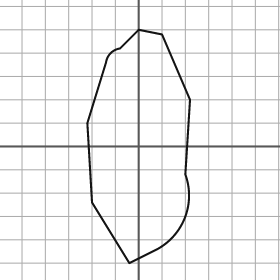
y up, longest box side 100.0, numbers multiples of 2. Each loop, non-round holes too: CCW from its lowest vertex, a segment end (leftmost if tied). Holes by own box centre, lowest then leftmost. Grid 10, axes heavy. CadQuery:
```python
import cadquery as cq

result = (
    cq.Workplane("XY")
    .moveTo(-4.0, -50.0)
    .lineTo(8.0, -44.0)
    .threePointArc((20.0, -30.0), (20.0, -12.0))
    .lineTo(22.0, 20.0)
    .lineTo(10.0, 48.0)
    .lineTo(0.0, 50.0)
    .lineTo(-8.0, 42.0)
    .threePointArc((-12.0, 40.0), (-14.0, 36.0))
    .lineTo(-22.0, 10.0)
    .lineTo(-20.0, -24.0)
    .close()
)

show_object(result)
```